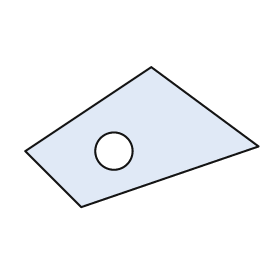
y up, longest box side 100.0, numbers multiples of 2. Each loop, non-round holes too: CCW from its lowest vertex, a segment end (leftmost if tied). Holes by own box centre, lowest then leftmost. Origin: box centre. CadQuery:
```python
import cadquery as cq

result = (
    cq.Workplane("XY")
    .moveTo(-26.0, -30.0)
    .lineTo(50.0, -4.0)
    .lineTo(4.0, 30.0)
    .lineTo(-50.0, -6.0)
    .close()
    .moveTo(-12.0, -6.0)
    .circle(8.0)
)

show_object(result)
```